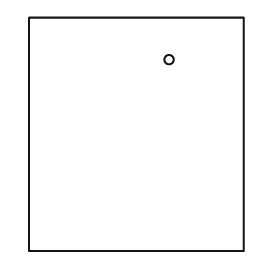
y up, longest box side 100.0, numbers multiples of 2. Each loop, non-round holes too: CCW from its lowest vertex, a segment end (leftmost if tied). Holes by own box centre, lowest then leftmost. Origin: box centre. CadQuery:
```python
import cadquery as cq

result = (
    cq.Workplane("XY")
    .moveTo(-46.0, -50.0)
    .lineTo(46.0, -50.0)
    .lineTo(46.0, 50.0)
    .lineTo(-46.0, 50.0)
    .close()
    .moveTo(14.0, 32.0)
    .circle(2.0)
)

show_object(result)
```